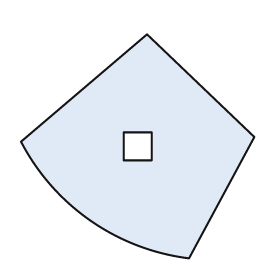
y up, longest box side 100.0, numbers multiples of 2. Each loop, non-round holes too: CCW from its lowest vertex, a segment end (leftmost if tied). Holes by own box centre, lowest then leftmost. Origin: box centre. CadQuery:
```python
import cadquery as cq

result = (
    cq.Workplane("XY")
    .moveTo(22.0, -48.0)
    .lineTo(50.0, 4.0)
    .lineTo(4.0, 48.0)
    .lineTo(-50.0, 2.0)
    .threePointArc((-20.0, -32.0), (22.0, -48.0))
    .close()
    .moveTo(-6.0, -6.0)
    .lineTo(6.0, -6.0)
    .lineTo(6.0, 6.0)
    .lineTo(-6.0, 6.0)
    .close()
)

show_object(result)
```